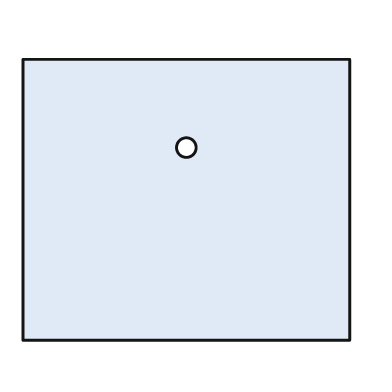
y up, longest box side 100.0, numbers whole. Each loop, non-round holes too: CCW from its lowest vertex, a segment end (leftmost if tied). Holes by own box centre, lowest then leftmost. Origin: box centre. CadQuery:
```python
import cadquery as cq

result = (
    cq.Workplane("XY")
    .moveTo(-50.0, -43.0)
    .lineTo(50.0, -43.0)
    .lineTo(50.0, 43.0)
    .lineTo(-50.0, 43.0)
    .close()
    .moveTo(0.0, 16.0)
    .circle(3.0)
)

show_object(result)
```